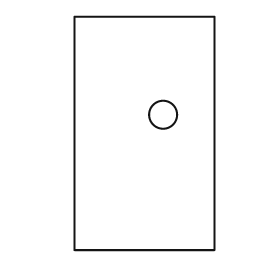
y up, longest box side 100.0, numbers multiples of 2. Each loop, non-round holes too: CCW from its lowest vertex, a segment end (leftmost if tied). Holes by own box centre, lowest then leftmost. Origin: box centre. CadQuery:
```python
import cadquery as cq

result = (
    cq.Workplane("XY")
    .moveTo(-30.0, -50.0)
    .lineTo(30.0, -50.0)
    .lineTo(30.0, 50.0)
    .lineTo(-30.0, 50.0)
    .close()
    .moveTo(8.0, 8.0)
    .circle(6.0)
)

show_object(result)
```